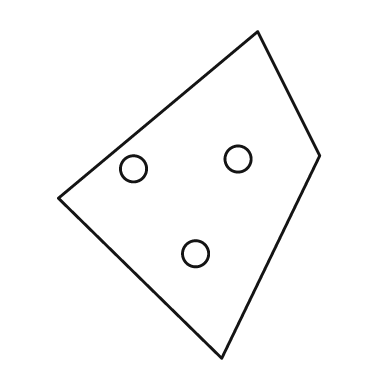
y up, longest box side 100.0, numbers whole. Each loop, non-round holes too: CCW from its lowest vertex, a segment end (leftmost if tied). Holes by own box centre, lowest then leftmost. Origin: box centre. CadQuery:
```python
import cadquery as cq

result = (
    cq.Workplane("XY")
    .moveTo(10.0, -50.0)
    .lineTo(40.0, 12.0)
    .lineTo(21.0, 50.0)
    .lineTo(-40.0, -1.0)
    .close()
    .moveTo(2.0, -18.0)
    .circle(4.0)
    .moveTo(-17.0, 8.0)
    .circle(4.0)
    .moveTo(15.0, 11.0)
    .circle(4.0)
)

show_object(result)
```